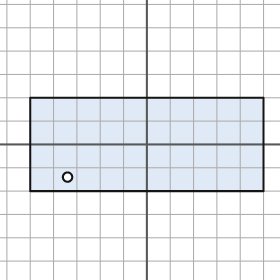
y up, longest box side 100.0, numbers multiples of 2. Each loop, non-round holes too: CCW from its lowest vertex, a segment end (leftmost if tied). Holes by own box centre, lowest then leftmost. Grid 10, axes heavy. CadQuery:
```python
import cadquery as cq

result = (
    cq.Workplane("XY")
    .moveTo(-50.0, -20.0)
    .lineTo(50.0, -20.0)
    .lineTo(50.0, 20.0)
    .lineTo(-50.0, 20.0)
    .close()
    .moveTo(-34.0, -14.0)
    .circle(2.0)
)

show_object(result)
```